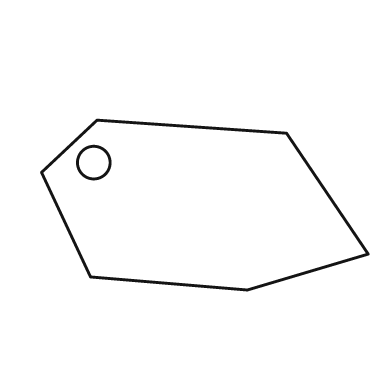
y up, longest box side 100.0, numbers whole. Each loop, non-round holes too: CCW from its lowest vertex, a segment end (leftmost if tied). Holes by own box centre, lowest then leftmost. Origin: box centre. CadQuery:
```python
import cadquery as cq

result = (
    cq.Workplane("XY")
    .moveTo(13.0, -26.0)
    .lineTo(50.0, -15.0)
    .lineTo(25.0, 22.0)
    .lineTo(-33.0, 26.0)
    .lineTo(-50.0, 10.0)
    .lineTo(-35.0, -22.0)
    .close()
    .moveTo(-34.0, 13.0)
    .circle(5.0)
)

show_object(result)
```